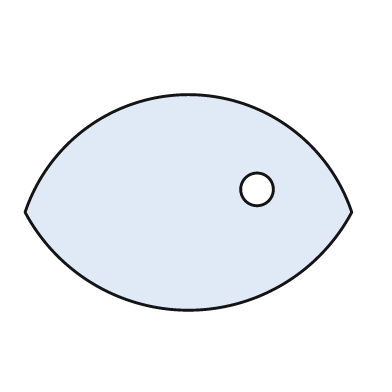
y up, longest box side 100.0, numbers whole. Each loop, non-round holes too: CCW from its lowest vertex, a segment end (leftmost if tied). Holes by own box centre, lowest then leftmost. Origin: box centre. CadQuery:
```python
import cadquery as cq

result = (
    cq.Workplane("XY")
    .moveTo(-50.0, -3.0)
    .threePointArc((0.0, -33.0), (50.0, -3.0))
    .threePointArc((0.0, 33.0), (-50.0, -3.0))
    .close()
    .moveTo(21.0, 4.0)
    .circle(5.0)
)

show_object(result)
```